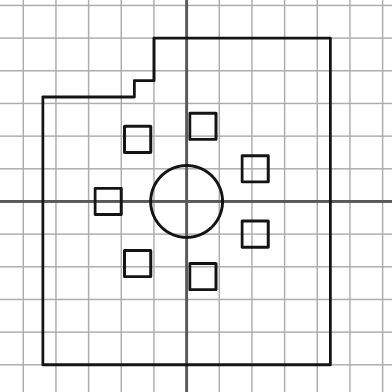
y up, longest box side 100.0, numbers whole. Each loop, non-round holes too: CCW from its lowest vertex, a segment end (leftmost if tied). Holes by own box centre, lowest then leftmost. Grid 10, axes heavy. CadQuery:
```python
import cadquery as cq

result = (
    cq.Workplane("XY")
    .moveTo(-44.0, -50.0)
    .lineTo(44.0, -50.0)
    .lineTo(44.0, 50.0)
    .lineTo(-10.0, 50.0)
    .lineTo(-10.0, 37.0)
    .lineTo(-16.0, 37.0)
    .lineTo(-16.0, 32.0)
    .lineTo(-44.0, 32.0)
    .close()
    .moveTo(1.0, -27.0)
    .lineTo(9.0, -27.0)
    .lineTo(9.0, -19.0)
    .lineTo(1.0, -19.0)
    .close()
    .moveTo(-19.0, -23.0)
    .lineTo(-11.0, -23.0)
    .lineTo(-11.0, -15.0)
    .lineTo(-19.0, -15.0)
    .close()
    .moveTo(17.0, -14.0)
    .lineTo(25.0, -14.0)
    .lineTo(25.0, -6.0)
    .lineTo(17.0, -6.0)
    .close()
    .moveTo(-28.0, -4.0)
    .lineTo(-20.0, -4.0)
    .lineTo(-20.0, 4.0)
    .lineTo(-28.0, 4.0)
    .close()
    .moveTo(0.0, 0.0)
    .circle(11.0)
    .moveTo(17.0, 6.0)
    .lineTo(25.0, 6.0)
    .lineTo(25.0, 14.0)
    .lineTo(17.0, 14.0)
    .close()
    .moveTo(-19.0, 15.0)
    .lineTo(-11.0, 15.0)
    .lineTo(-11.0, 23.0)
    .lineTo(-19.0, 23.0)
    .close()
    .moveTo(1.0, 19.0)
    .lineTo(9.0, 19.0)
    .lineTo(9.0, 27.0)
    .lineTo(1.0, 27.0)
    .close()
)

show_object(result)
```